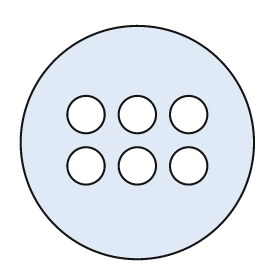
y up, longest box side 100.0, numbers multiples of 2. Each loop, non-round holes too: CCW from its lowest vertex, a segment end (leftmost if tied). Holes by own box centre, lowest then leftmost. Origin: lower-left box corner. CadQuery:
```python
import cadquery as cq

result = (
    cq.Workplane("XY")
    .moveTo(50.0, 50.0)
    .circle(50.0)
    .moveTo(28.0, 40.0)
    .circle(8.0)
    .moveTo(50.0, 40.0)
    .circle(8.0)
    .moveTo(72.0, 40.0)
    .circle(8.0)
    .moveTo(28.0, 62.0)
    .circle(8.0)
    .moveTo(50.0, 62.0)
    .circle(8.0)
    .moveTo(72.0, 62.0)
    .circle(8.0)
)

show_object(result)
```